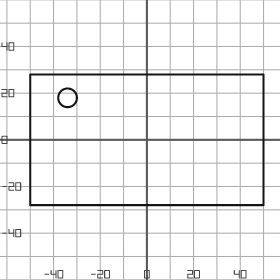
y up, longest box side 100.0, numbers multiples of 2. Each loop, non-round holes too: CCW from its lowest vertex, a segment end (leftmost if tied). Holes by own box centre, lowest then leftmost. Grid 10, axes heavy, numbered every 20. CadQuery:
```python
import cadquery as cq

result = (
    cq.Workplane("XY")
    .moveTo(-50.0, -28.0)
    .lineTo(50.0, -28.0)
    .lineTo(50.0, 28.0)
    .lineTo(-50.0, 28.0)
    .close()
    .moveTo(-34.0, 18.0)
    .circle(4.0)
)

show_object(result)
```